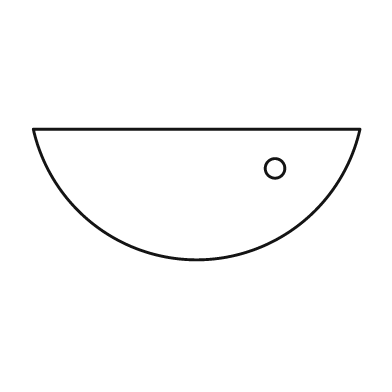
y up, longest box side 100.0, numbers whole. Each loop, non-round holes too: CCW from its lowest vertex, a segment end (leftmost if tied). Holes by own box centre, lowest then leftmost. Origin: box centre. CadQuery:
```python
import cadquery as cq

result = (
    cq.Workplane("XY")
    .moveTo(-50.0, 20.0)
    .threePointArc((0.0, -20.0), (50.0, 20.0))
    .close()
    .moveTo(24.0, 8.0)
    .circle(3.0)
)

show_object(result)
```